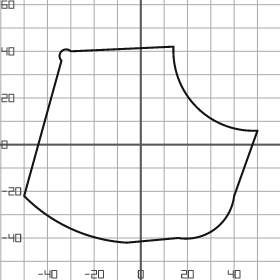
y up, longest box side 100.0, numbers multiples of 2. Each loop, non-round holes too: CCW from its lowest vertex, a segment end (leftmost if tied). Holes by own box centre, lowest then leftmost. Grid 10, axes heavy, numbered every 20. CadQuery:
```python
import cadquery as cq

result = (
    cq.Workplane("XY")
    .moveTo(-6.0, -42.0)
    .lineTo(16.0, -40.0)
    .threePointArc((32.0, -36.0), (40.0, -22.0))
    .lineTo(50.0, 6.0)
    .threePointArc((24.0, 16.0), (14.0, 42.0))
    .lineTo(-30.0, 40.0)
    .threePointArc((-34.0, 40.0), (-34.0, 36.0))
    .lineTo(-50.0, -22.0)
    .threePointArc((-30.0, -36.0), (-6.0, -42.0))
    .close()
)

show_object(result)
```